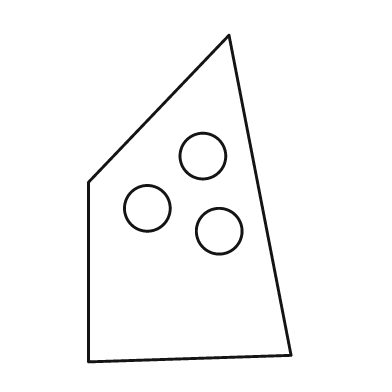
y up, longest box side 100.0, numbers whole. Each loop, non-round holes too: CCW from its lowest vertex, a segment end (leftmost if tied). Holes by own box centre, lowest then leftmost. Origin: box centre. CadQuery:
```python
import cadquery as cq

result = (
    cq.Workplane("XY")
    .moveTo(-31.0, -50.0)
    .lineTo(31.0, -48.0)
    .lineTo(12.0, 50.0)
    .lineTo(-31.0, 5.0)
    .close()
    .moveTo(9.0, -10.0)
    .circle(7.0)
    .moveTo(-13.0, -3.0)
    .circle(7.0)
    .moveTo(4.0, 13.0)
    .circle(7.0)
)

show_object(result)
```